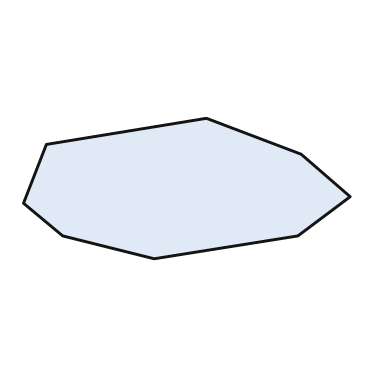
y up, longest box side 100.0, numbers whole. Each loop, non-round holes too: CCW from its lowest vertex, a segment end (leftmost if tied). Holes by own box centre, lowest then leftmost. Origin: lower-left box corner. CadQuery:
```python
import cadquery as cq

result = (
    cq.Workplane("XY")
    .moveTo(40.0, 0.0)
    .lineTo(84.0, 7.0)
    .lineTo(100.0, 19.0)
    .lineTo(85.0, 32.0)
    .lineTo(56.0, 43.0)
    .lineTo(7.0, 35.0)
    .lineTo(0.0, 17.0)
    .lineTo(12.0, 7.0)
    .close()
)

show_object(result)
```